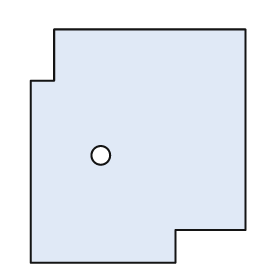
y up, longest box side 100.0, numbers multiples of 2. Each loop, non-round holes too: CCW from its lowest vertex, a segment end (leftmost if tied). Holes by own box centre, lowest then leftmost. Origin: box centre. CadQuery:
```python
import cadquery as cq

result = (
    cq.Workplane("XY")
    .moveTo(-46.0, -50.0)
    .lineTo(16.0, -50.0)
    .lineTo(16.0, -36.0)
    .lineTo(46.0, -36.0)
    .lineTo(46.0, 50.0)
    .lineTo(-36.0, 50.0)
    .lineTo(-36.0, 28.0)
    .lineTo(-46.0, 28.0)
    .close()
    .moveTo(-16.0, -4.0)
    .circle(4.0)
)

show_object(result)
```